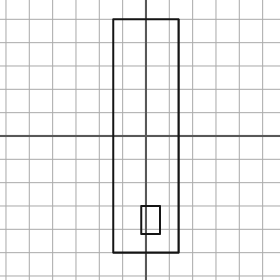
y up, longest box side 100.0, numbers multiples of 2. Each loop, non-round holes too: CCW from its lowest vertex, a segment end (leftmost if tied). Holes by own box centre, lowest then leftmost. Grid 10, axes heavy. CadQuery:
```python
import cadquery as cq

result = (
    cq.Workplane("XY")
    .moveTo(-14.0, -50.0)
    .lineTo(14.0, -50.0)
    .lineTo(14.0, 50.0)
    .lineTo(-14.0, 50.0)
    .close()
    .moveTo(-2.0, -42.0)
    .lineTo(6.0, -42.0)
    .lineTo(6.0, -30.0)
    .lineTo(-2.0, -30.0)
    .close()
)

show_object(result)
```